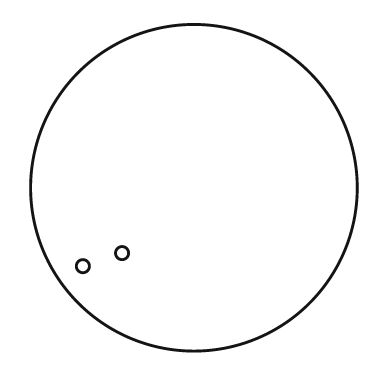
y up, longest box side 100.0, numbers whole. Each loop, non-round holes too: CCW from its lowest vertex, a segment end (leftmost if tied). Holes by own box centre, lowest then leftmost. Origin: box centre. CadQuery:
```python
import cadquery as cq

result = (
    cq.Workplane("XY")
    .moveTo(0.0, 0.0)
    .circle(50.0)
    .moveTo(-34.0, -24.0)
    .circle(2.0)
    .moveTo(-22.0, -20.0)
    .circle(2.0)
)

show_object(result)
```